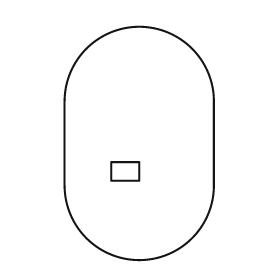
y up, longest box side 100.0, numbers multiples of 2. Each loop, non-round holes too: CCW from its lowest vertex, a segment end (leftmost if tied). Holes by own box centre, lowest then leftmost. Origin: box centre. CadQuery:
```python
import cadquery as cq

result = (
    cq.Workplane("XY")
    .moveTo(-32.0, -18.0)
    .threePointArc((0.0, -50.0), (32.0, -18.0))
    .lineTo(32.0, 18.0)
    .threePointArc((0.0, 50.0), (-32.0, 18.0))
    .close()
    .moveTo(-12.0, -16.0)
    .lineTo(0.0, -16.0)
    .lineTo(0.0, -8.0)
    .lineTo(-12.0, -8.0)
    .close()
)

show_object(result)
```